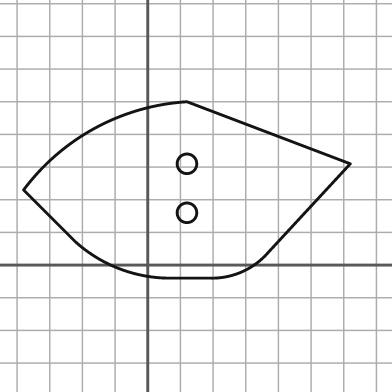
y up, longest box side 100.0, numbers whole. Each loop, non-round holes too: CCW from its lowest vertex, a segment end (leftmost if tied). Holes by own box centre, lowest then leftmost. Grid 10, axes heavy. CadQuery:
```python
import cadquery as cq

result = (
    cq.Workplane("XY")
    .moveTo(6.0, -4.0)
    .lineTo(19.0, -4.0)
    .threePointArc((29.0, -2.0), (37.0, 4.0))
    .lineTo(62.0, 31.0)
    .lineTo(12.0, 50.0)
    .threePointArc((-16.0, 42.0), (-38.0, 23.0))
    .lineTo(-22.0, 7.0)
    .threePointArc((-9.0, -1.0), (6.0, -4.0))
    .close()
    .moveTo(12.0, 16.0)
    .circle(3.0)
    .moveTo(12.0, 31.0)
    .circle(3.0)
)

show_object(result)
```